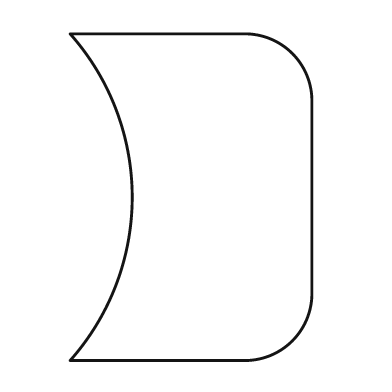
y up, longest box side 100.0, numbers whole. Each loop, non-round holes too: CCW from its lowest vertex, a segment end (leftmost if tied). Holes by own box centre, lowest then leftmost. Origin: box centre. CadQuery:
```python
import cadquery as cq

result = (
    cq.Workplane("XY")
    .moveTo(-37.0, -50.0)
    .lineTo(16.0, -50.0)
    .threePointArc((31.0, -44.0), (37.0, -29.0))
    .lineTo(37.0, 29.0)
    .threePointArc((31.0, 44.0), (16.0, 50.0))
    .lineTo(-37.0, 50.0)
    .threePointArc((-18.0, 0.0), (-37.0, -50.0))
    .close()
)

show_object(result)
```